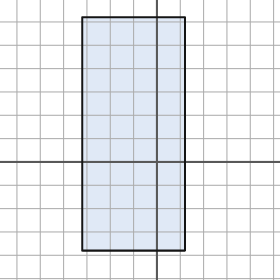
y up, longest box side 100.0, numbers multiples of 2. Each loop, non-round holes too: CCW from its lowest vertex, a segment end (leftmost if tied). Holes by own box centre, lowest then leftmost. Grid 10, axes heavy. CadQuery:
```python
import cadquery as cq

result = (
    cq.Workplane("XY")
    .moveTo(-32.0, -38.0)
    .lineTo(12.0, -38.0)
    .lineTo(12.0, 62.0)
    .lineTo(-32.0, 62.0)
    .close()
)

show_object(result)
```